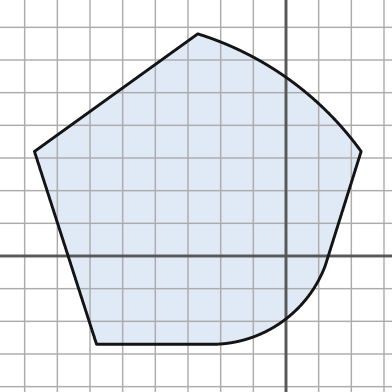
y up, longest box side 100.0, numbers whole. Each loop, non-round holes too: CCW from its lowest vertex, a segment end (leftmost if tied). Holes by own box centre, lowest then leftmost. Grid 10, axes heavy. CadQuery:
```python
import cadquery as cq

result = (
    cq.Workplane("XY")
    .moveTo(-58.0, -27.0)
    .lineTo(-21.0, -27.0)
    .threePointArc((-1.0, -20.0), (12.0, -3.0))
    .lineTo(23.0, 32.0)
    .threePointArc((1.0, 54.0), (-27.0, 68.0))
    .lineTo(-77.0, 32.0)
    .close()
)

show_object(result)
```